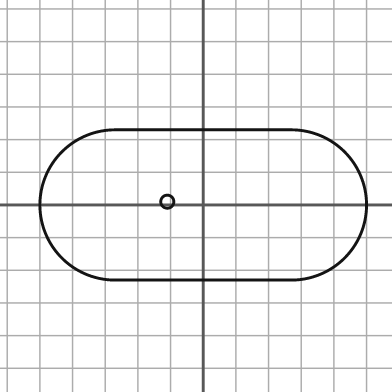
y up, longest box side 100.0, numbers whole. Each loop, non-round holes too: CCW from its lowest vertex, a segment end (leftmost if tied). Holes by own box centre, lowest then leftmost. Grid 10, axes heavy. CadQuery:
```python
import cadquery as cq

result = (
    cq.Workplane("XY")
    .moveTo(-27.0, -23.0)
    .lineTo(27.0, -23.0)
    .threePointArc((50.0, 0.0), (27.0, 23.0))
    .lineTo(-27.0, 23.0)
    .threePointArc((-50.0, 0.0), (-27.0, -23.0))
    .close()
    .moveTo(-11.0, 1.0)
    .circle(2.0)
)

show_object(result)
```